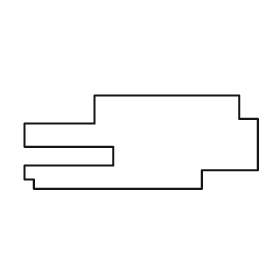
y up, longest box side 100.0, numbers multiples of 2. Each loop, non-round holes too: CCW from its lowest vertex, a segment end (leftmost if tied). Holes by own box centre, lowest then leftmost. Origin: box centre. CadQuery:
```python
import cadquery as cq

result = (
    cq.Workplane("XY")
    .moveTo(-46.0, -20.0)
    .lineTo(26.0, -20.0)
    .lineTo(26.0, -12.0)
    .lineTo(50.0, -12.0)
    .lineTo(50.0, 10.0)
    .lineTo(42.0, 10.0)
    .lineTo(42.0, 20.0)
    .lineTo(-20.0, 20.0)
    .lineTo(-20.0, 8.0)
    .lineTo(-50.0, 8.0)
    .lineTo(-50.0, -2.0)
    .lineTo(-12.0, -2.0)
    .lineTo(-12.0, -10.0)
    .lineTo(-50.0, -10.0)
    .lineTo(-50.0, -16.0)
    .lineTo(-46.0, -16.0)
    .close()
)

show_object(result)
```